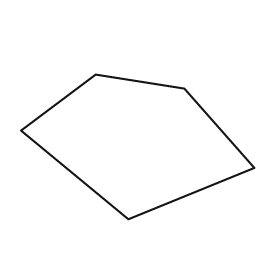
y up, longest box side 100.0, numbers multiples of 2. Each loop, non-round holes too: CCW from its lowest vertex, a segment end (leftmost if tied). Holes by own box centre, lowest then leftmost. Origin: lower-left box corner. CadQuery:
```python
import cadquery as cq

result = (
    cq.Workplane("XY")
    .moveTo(46.0, 0.0)
    .lineTo(100.0, 22.0)
    .lineTo(70.0, 56.0)
    .lineTo(32.0, 62.0)
    .lineTo(0.0, 38.0)
    .close()
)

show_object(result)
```